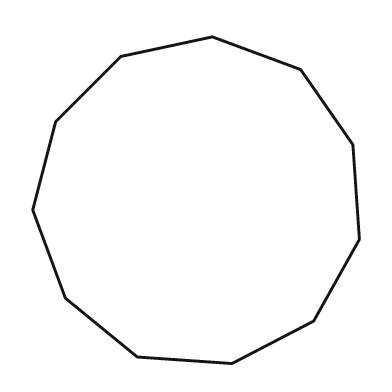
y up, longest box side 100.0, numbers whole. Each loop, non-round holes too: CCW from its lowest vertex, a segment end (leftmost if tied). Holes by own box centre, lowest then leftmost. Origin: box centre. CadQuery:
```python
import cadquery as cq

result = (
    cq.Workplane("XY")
    .moveTo(11.0, -50.0)
    .lineTo(36.0, -37.0)
    .lineTo(50.0, -12.0)
    .lineTo(48.0, 17.0)
    .lineTo(32.0, 40.0)
    .lineTo(5.0, 50.0)
    .lineTo(-23.0, 44.0)
    .lineTo(-43.0, 24.0)
    .lineTo(-50.0, -3.0)
    .lineTo(-40.0, -30.0)
    .lineTo(-18.0, -48.0)
    .close()
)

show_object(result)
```